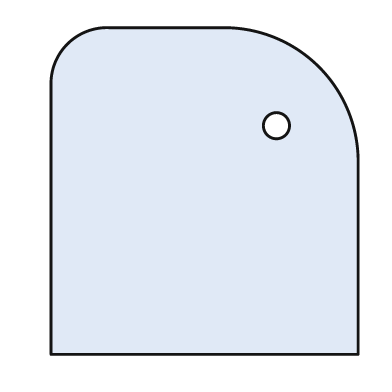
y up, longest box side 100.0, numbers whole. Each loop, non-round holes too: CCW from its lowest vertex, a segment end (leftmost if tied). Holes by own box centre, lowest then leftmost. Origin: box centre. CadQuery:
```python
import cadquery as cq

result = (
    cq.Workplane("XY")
    .moveTo(-47.0, -50.0)
    .lineTo(47.0, -50.0)
    .lineTo(47.0, 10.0)
    .threePointArc((35.0, 38.0), (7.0, 50.0))
    .lineTo(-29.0, 50.0)
    .threePointArc((-42.0, 45.0), (-47.0, 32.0))
    .close()
    .moveTo(22.0, 20.0)
    .circle(4.0)
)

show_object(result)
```